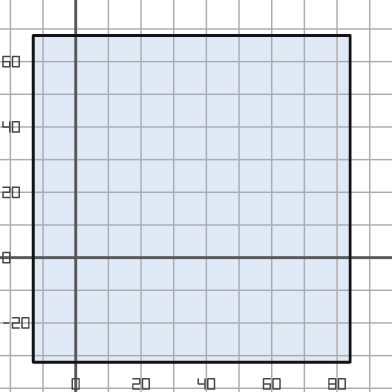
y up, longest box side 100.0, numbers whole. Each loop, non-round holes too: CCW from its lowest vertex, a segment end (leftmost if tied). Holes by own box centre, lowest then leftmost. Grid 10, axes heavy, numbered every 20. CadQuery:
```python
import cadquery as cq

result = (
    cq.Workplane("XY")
    .moveTo(-13.0, -32.0)
    .lineTo(84.0, -32.0)
    .lineTo(84.0, 68.0)
    .lineTo(-13.0, 68.0)
    .close()
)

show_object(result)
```